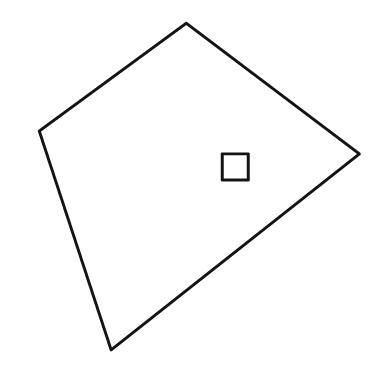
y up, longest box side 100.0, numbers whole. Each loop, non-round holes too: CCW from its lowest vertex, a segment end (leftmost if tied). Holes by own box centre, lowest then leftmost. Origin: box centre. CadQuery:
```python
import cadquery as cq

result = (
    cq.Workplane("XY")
    .moveTo(-27.0, -50.0)
    .lineTo(49.0, 10.0)
    .lineTo(-4.0, 50.0)
    .lineTo(-49.0, 17.0)
    .close()
    .moveTo(7.0, 2.0)
    .lineTo(15.0, 2.0)
    .lineTo(15.0, 10.0)
    .lineTo(7.0, 10.0)
    .close()
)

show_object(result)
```